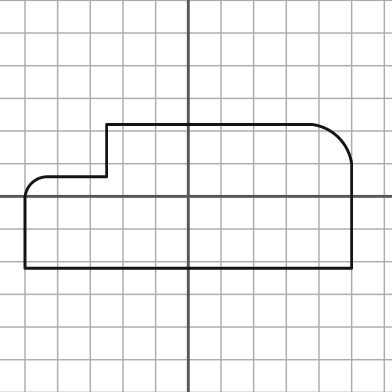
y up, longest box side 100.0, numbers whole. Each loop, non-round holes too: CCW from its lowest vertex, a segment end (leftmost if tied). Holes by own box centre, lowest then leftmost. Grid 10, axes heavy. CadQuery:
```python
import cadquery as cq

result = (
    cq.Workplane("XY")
    .moveTo(-50.0, -22.0)
    .lineTo(50.0, -22.0)
    .lineTo(50.0, 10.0)
    .threePointArc((46.0, 18.0), (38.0, 22.0))
    .lineTo(-25.0, 22.0)
    .lineTo(-25.0, 6.0)
    .lineTo(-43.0, 6.0)
    .threePointArc((-48.0, 4.0), (-50.0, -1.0))
    .close()
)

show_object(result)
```